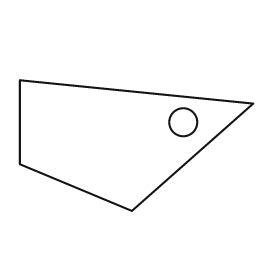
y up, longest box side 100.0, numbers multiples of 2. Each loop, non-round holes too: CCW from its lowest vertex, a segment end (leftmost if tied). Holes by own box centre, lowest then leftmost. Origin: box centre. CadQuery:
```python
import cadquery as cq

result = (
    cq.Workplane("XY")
    .moveTo(-2.0, -28.0)
    .lineTo(50.0, 18.0)
    .lineTo(-50.0, 28.0)
    .lineTo(-50.0, -8.0)
    .close()
    .moveTo(20.0, 10.0)
    .circle(6.0)
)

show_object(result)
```